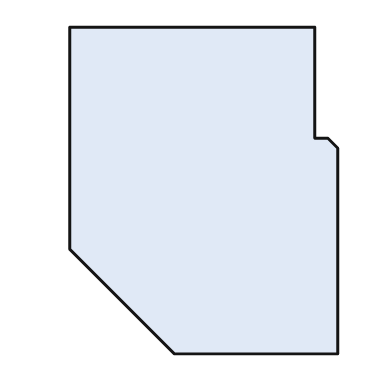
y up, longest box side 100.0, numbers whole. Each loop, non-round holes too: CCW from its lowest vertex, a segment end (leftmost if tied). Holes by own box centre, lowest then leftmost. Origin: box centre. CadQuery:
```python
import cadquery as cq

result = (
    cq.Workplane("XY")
    .moveTo(-9.0, -50.0)
    .lineTo(41.0, -50.0)
    .lineTo(41.0, 13.0)
    .lineTo(38.0, 16.0)
    .lineTo(34.0, 16.0)
    .lineTo(34.0, 50.0)
    .lineTo(-41.0, 50.0)
    .lineTo(-41.0, -18.0)
    .close()
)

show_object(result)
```